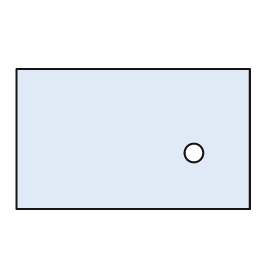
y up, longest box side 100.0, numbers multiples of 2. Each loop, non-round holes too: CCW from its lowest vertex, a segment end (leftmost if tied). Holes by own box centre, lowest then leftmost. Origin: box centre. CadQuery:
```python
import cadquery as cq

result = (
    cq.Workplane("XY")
    .moveTo(-50.0, -30.0)
    .lineTo(50.0, -30.0)
    .lineTo(50.0, 30.0)
    .lineTo(-50.0, 30.0)
    .close()
    .moveTo(26.0, -6.0)
    .circle(4.0)
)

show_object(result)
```